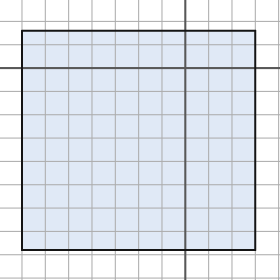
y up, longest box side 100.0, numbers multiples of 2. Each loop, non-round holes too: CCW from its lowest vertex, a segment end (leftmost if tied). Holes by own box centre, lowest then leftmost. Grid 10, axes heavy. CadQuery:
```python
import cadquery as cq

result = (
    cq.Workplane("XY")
    .moveTo(-70.0, -78.0)
    .lineTo(30.0, -78.0)
    .lineTo(30.0, 16.0)
    .lineTo(-70.0, 16.0)
    .close()
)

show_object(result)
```